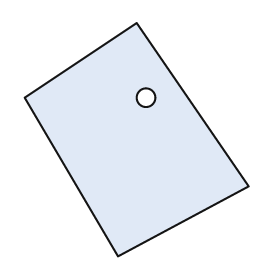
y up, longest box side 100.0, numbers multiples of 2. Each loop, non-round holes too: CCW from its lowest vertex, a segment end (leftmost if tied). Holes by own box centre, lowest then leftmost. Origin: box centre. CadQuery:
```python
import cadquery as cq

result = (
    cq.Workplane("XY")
    .moveTo(-8.0, -50.0)
    .lineTo(48.0, -20.0)
    .lineTo(0.0, 50.0)
    .lineTo(-48.0, 18.0)
    .close()
    .moveTo(4.0, 18.0)
    .circle(4.0)
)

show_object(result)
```